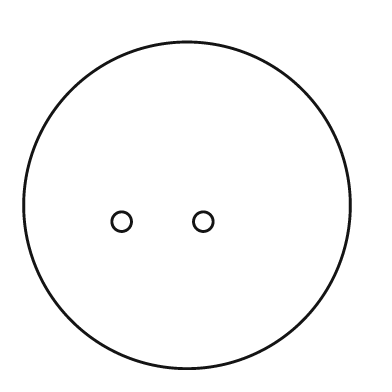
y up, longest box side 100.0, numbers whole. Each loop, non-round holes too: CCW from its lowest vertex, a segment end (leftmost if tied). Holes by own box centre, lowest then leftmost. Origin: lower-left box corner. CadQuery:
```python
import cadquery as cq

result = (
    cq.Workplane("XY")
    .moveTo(50.0, 50.0)
    .circle(50.0)
    .moveTo(30.0, 45.0)
    .circle(3.0)
    .moveTo(55.0, 45.0)
    .circle(3.0)
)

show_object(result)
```